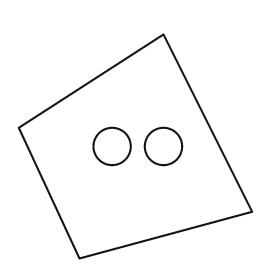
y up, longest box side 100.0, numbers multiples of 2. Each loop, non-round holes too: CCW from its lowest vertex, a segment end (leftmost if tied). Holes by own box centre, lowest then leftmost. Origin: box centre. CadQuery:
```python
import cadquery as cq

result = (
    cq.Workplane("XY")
    .moveTo(-24.0, -48.0)
    .lineTo(50.0, -28.0)
    .lineTo(12.0, 48.0)
    .lineTo(-50.0, 8.0)
    .close()
    .moveTo(-10.0, 0.0)
    .circle(8.0)
    .moveTo(12.0, 0.0)
    .circle(8.0)
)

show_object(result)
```